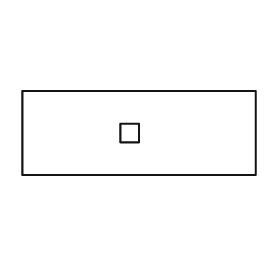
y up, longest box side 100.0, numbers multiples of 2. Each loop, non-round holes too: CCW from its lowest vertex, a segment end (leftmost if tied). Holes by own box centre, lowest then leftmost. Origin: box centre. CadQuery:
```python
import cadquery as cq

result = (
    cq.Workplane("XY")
    .moveTo(-50.0, -18.0)
    .lineTo(50.0, -18.0)
    .lineTo(50.0, 18.0)
    .lineTo(-50.0, 18.0)
    .close()
    .moveTo(-8.0, -4.0)
    .lineTo(0.0, -4.0)
    .lineTo(0.0, 4.0)
    .lineTo(-8.0, 4.0)
    .close()
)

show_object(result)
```